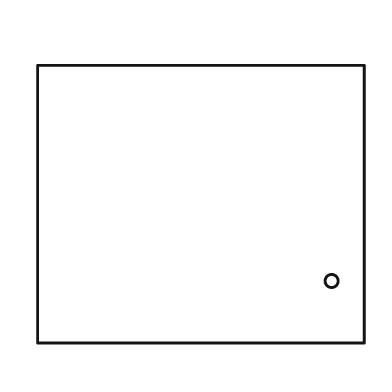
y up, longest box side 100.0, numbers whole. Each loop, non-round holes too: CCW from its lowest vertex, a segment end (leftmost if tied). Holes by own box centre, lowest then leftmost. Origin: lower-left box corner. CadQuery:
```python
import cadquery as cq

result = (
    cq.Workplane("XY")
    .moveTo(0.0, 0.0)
    .lineTo(100.0, 0.0)
    .lineTo(100.0, 85.0)
    .lineTo(0.0, 85.0)
    .close()
    .moveTo(90.0, 19.0)
    .circle(2.0)
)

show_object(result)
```